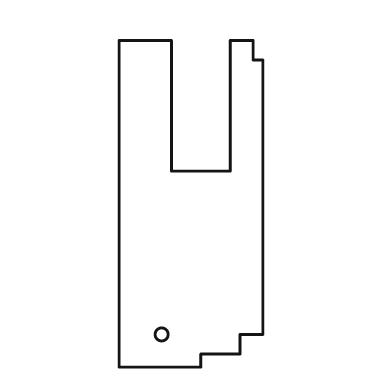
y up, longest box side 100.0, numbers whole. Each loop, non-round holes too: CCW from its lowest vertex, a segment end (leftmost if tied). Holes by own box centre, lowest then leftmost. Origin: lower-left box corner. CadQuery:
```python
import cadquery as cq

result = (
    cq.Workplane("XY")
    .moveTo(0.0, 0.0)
    .lineTo(25.0, 0.0)
    .lineTo(25.0, 4.0)
    .lineTo(37.0, 4.0)
    .lineTo(37.0, 10.0)
    .lineTo(44.0, 10.0)
    .lineTo(44.0, 94.0)
    .lineTo(41.0, 94.0)
    .lineTo(41.0, 100.0)
    .lineTo(34.0, 100.0)
    .lineTo(34.0, 60.0)
    .lineTo(16.0, 60.0)
    .lineTo(16.0, 100.0)
    .lineTo(0.0, 100.0)
    .close()
    .moveTo(13.0, 10.0)
    .circle(2.0)
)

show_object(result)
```